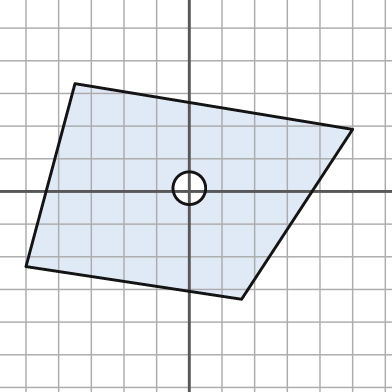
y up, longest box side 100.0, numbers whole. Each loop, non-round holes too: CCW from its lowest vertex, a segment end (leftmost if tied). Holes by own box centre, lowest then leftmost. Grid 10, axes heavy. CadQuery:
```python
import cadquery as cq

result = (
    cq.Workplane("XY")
    .moveTo(16.0, -33.0)
    .lineTo(50.0, 19.0)
    .lineTo(-35.0, 33.0)
    .lineTo(-50.0, -23.0)
    .close()
    .moveTo(0.0, 1.0)
    .circle(5.0)
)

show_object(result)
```